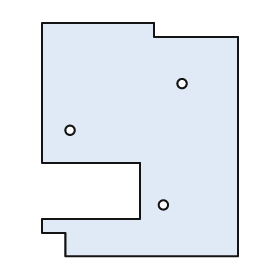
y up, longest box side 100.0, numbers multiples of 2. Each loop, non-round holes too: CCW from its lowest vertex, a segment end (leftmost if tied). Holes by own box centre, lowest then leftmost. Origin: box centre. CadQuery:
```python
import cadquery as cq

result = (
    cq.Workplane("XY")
    .moveTo(-32.0, -50.0)
    .lineTo(42.0, -50.0)
    .lineTo(42.0, 44.0)
    .lineTo(6.0, 44.0)
    .lineTo(6.0, 50.0)
    .lineTo(-42.0, 50.0)
    .lineTo(-42.0, -10.0)
    .lineTo(0.0, -10.0)
    .lineTo(0.0, -34.0)
    .lineTo(-42.0, -34.0)
    .lineTo(-42.0, -40.0)
    .lineTo(-32.0, -40.0)
    .close()
    .moveTo(10.0, -28.0)
    .circle(2.0)
    .moveTo(-30.0, 4.0)
    .circle(2.0)
    .moveTo(18.0, 24.0)
    .circle(2.0)
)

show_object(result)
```